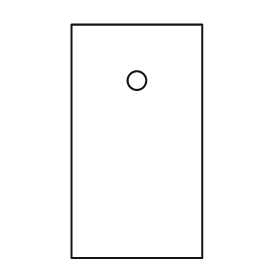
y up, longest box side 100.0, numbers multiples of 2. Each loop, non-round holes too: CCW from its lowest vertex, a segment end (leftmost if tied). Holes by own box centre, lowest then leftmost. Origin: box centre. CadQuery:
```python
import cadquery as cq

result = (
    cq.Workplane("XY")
    .moveTo(-28.0, -50.0)
    .lineTo(28.0, -50.0)
    .lineTo(28.0, 50.0)
    .lineTo(-28.0, 50.0)
    .close()
    .moveTo(0.0, 26.0)
    .circle(4.0)
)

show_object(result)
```